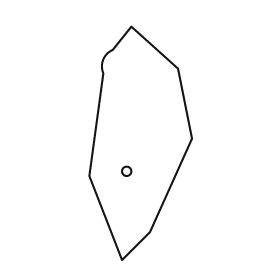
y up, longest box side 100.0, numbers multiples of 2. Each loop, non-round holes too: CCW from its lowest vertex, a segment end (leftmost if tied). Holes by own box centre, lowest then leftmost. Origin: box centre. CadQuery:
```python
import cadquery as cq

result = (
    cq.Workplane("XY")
    .moveTo(-8.0, -50.0)
    .lineTo(4.0, -38.0)
    .lineTo(22.0, 2.0)
    .lineTo(16.0, 32.0)
    .lineTo(-4.0, 50.0)
    .lineTo(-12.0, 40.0)
    .threePointArc((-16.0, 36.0), (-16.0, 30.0))
    .lineTo(-22.0, -14.0)
    .close()
    .moveTo(-6.0, -12.0)
    .circle(2.0)
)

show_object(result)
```